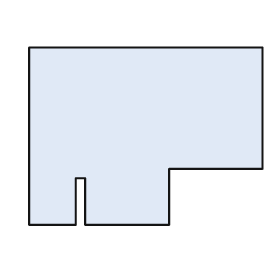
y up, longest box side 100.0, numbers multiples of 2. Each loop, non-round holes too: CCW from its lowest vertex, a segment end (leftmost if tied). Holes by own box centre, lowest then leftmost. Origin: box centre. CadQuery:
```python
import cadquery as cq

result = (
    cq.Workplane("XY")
    .moveTo(-50.0, -38.0)
    .lineTo(-30.0, -38.0)
    .lineTo(-30.0, -18.0)
    .lineTo(-26.0, -18.0)
    .lineTo(-26.0, -38.0)
    .lineTo(10.0, -38.0)
    .lineTo(10.0, -14.0)
    .lineTo(50.0, -14.0)
    .lineTo(50.0, 38.0)
    .lineTo(-50.0, 38.0)
    .close()
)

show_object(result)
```